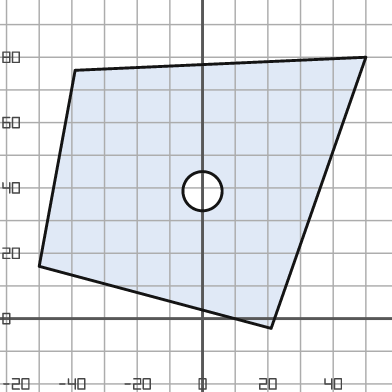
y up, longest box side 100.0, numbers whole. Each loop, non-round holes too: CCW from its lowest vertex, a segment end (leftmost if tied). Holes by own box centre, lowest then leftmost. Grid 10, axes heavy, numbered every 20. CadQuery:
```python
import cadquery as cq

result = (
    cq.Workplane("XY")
    .moveTo(21.0, -3.0)
    .lineTo(50.0, 80.0)
    .lineTo(-39.0, 76.0)
    .lineTo(-50.0, 16.0)
    .close()
    .moveTo(0.0, 39.0)
    .circle(6.0)
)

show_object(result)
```